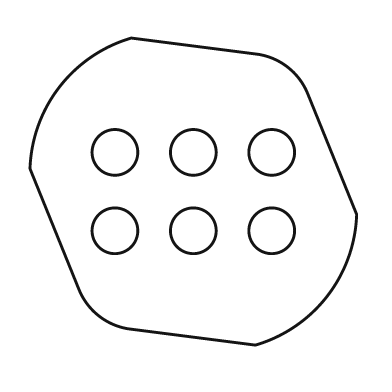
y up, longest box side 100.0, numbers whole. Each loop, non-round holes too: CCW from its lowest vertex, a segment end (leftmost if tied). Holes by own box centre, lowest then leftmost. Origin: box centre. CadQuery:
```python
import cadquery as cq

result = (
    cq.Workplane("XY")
    .moveTo(19.0, -47.0)
    .threePointArc((41.0, -32.0), (50.0, -7.0))
    .lineTo(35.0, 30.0)
    .threePointArc((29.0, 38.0), (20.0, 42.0))
    .lineTo(-19.0, 47.0)
    .threePointArc((-41.0, 32.0), (-50.0, 7.0))
    .lineTo(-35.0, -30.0)
    .threePointArc((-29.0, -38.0), (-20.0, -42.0))
    .close()
    .moveTo(-24.0, -12.0)
    .circle(7.0)
    .moveTo(0.0, -12.0)
    .circle(7.0)
    .moveTo(24.0, -12.0)
    .circle(7.0)
    .moveTo(-24.0, 12.0)
    .circle(7.0)
    .moveTo(0.0, 12.0)
    .circle(7.0)
    .moveTo(24.0, 12.0)
    .circle(7.0)
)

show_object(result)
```